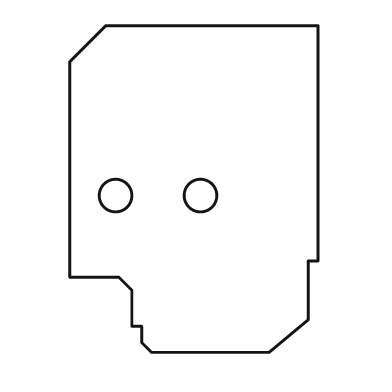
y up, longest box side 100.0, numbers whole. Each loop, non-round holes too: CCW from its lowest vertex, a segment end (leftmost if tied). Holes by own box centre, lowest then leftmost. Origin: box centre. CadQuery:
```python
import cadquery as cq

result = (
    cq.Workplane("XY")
    .moveTo(-13.0, -50.0)
    .lineTo(23.0, -50.0)
    .lineTo(35.0, -40.0)
    .lineTo(35.0, -22.0)
    .lineTo(38.0, -22.0)
    .lineTo(38.0, 50.0)
    .lineTo(-27.0, 50.0)
    .lineTo(-38.0, 39.0)
    .lineTo(-38.0, -27.0)
    .lineTo(-23.0, -27.0)
    .lineTo(-19.0, -31.0)
    .lineTo(-19.0, -42.0)
    .lineTo(-16.0, -42.0)
    .lineTo(-16.0, -47.0)
    .close()
    .moveTo(-24.0, -2.0)
    .circle(5.0)
    .moveTo(2.0, -2.0)
    .circle(5.0)
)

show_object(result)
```